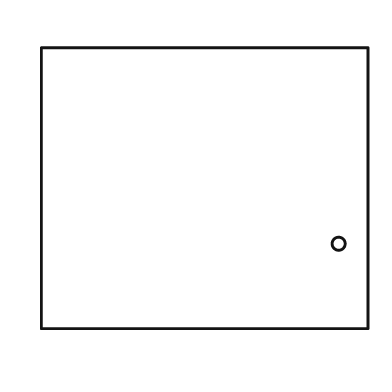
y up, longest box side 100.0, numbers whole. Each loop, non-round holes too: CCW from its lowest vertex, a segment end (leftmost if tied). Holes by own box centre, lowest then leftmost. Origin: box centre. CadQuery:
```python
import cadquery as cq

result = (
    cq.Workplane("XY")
    .moveTo(-50.0, -43.0)
    .lineTo(50.0, -43.0)
    .lineTo(50.0, 43.0)
    .lineTo(-50.0, 43.0)
    .close()
    .moveTo(41.0, -17.0)
    .circle(2.0)
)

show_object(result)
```